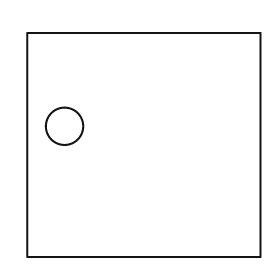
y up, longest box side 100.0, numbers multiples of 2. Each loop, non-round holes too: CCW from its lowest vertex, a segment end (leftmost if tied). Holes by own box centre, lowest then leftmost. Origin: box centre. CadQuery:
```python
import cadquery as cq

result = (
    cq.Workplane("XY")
    .moveTo(-50.0, -48.0)
    .lineTo(50.0, -48.0)
    .lineTo(50.0, 48.0)
    .lineTo(-50.0, 48.0)
    .close()
    .moveTo(-34.0, 8.0)
    .circle(8.0)
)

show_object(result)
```